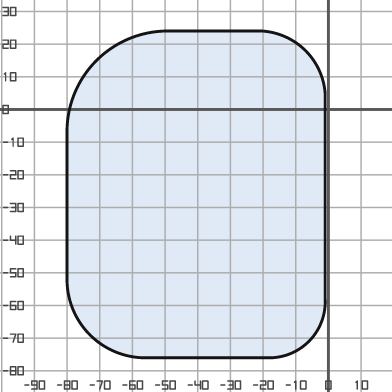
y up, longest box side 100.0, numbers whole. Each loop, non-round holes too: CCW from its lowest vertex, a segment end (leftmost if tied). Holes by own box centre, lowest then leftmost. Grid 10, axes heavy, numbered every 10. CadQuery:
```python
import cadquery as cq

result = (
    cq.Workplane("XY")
    .moveTo(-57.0, -76.0)
    .lineTo(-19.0, -76.0)
    .threePointArc((-6.0, -71.0), (-1.0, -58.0))
    .lineTo(-1.0, 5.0)
    .threePointArc((-7.0, 18.0), (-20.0, 24.0))
    .lineTo(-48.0, 24.0)
    .threePointArc((-71.0, 15.0), (-80.0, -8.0))
    .lineTo(-80.0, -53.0)
    .threePointArc((-73.0, -69.0), (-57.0, -76.0))
    .close()
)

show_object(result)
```